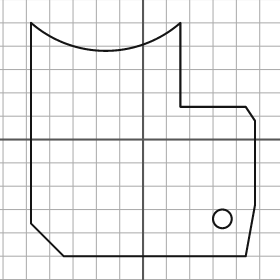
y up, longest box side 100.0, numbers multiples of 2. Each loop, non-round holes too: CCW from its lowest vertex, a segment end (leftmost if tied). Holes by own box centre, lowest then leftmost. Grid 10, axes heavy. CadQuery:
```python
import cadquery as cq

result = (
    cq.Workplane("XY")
    .moveTo(-34.0, -50.0)
    .lineTo(44.0, -50.0)
    .lineTo(48.0, -28.0)
    .lineTo(48.0, 8.0)
    .lineTo(44.0, 14.0)
    .lineTo(16.0, 14.0)
    .lineTo(16.0, 50.0)
    .threePointArc((-16.0, 38.0), (-48.0, 50.0))
    .lineTo(-48.0, -36.0)
    .close()
    .moveTo(34.0, -34.0)
    .circle(4.0)
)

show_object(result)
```